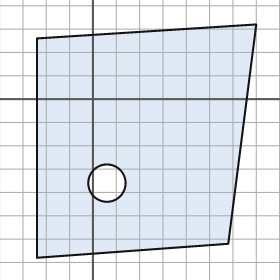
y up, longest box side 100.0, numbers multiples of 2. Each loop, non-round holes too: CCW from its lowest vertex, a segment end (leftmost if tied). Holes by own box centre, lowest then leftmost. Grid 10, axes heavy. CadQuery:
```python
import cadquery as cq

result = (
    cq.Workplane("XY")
    .moveTo(-24.0, -68.0)
    .lineTo(58.0, -62.0)
    .lineTo(70.0, 32.0)
    .lineTo(-24.0, 26.0)
    .close()
    .moveTo(6.0, -36.0)
    .circle(8.0)
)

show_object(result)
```